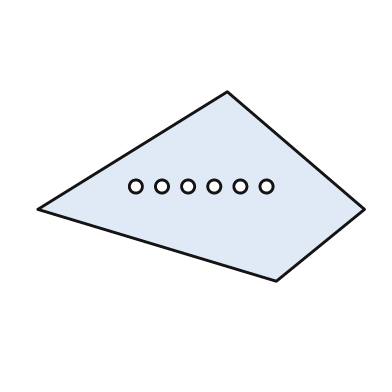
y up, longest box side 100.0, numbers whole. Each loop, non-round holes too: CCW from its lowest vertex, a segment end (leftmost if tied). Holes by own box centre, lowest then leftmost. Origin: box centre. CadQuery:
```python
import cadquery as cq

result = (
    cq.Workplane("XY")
    .moveTo(23.0, -29.0)
    .lineTo(50.0, -7.0)
    .lineTo(8.0, 29.0)
    .lineTo(-50.0, -7.0)
    .close()
    .moveTo(-20.0, 0.0)
    .circle(2.0)
    .moveTo(-12.0, 0.0)
    .circle(2.0)
    .moveTo(-4.0, 0.0)
    .circle(2.0)
    .moveTo(4.0, 0.0)
    .circle(2.0)
    .moveTo(12.0, 0.0)
    .circle(2.0)
    .moveTo(20.0, 0.0)
    .circle(2.0)
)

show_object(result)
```